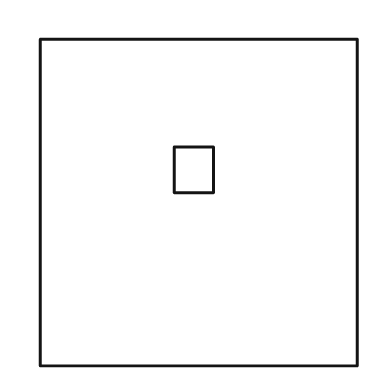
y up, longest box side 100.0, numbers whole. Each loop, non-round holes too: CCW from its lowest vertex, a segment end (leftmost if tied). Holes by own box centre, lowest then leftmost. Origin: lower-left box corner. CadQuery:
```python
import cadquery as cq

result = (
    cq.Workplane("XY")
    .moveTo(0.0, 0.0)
    .lineTo(97.0, 0.0)
    .lineTo(97.0, 100.0)
    .lineTo(0.0, 100.0)
    .close()
    .moveTo(41.0, 53.0)
    .lineTo(53.0, 53.0)
    .lineTo(53.0, 67.0)
    .lineTo(41.0, 67.0)
    .close()
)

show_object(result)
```